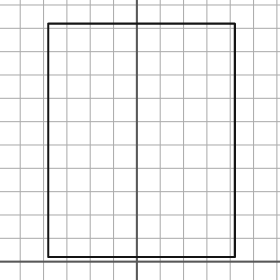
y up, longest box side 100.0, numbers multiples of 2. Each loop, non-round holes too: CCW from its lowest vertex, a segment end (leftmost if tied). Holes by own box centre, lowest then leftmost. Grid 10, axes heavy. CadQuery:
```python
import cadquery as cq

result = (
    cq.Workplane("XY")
    .moveTo(-38.0, 2.0)
    .lineTo(42.0, 2.0)
    .lineTo(42.0, 102.0)
    .lineTo(-38.0, 102.0)
    .close()
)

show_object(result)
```